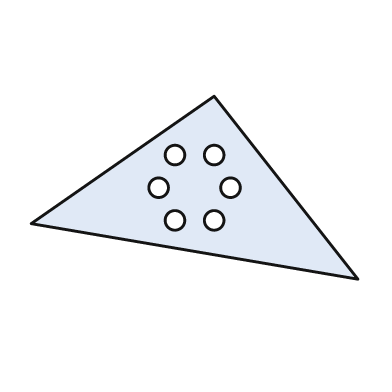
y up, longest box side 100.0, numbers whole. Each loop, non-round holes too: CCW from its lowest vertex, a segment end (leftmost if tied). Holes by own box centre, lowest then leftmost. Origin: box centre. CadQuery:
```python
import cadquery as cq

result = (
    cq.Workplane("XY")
    .moveTo(50.0, -28.0)
    .lineTo(6.0, 28.0)
    .lineTo(-50.0, -11.0)
    .close()
    .moveTo(-6.0, -10.0)
    .circle(3.0)
    .moveTo(6.0, -10.0)
    .circle(3.0)
    .moveTo(-11.0, 0.0)
    .circle(3.0)
    .moveTo(11.0, 0.0)
    .circle(3.0)
    .moveTo(-6.0, 10.0)
    .circle(3.0)
    .moveTo(6.0, 10.0)
    .circle(3.0)
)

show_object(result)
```